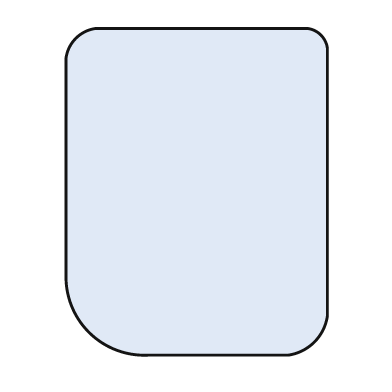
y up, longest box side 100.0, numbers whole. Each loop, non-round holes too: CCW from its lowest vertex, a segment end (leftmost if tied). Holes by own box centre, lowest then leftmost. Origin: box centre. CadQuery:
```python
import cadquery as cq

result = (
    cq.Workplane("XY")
    .moveTo(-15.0, -50.0)
    .lineTo(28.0, -50.0)
    .threePointArc((36.0, -46.0), (40.0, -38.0))
    .lineTo(40.0, 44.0)
    .threePointArc((38.0, 48.0), (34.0, 50.0))
    .lineTo(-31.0, 50.0)
    .threePointArc((-37.0, 47.0), (-40.0, 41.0))
    .lineTo(-40.0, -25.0)
    .threePointArc((-33.0, -43.0), (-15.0, -50.0))
    .close()
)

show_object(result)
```